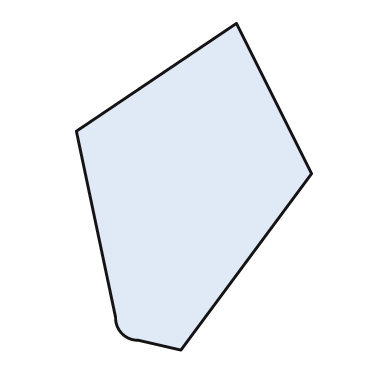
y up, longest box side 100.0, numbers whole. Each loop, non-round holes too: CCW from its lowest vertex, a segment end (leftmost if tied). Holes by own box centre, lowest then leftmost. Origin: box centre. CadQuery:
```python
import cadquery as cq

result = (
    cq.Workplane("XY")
    .moveTo(-4.0, -50.0)
    .lineTo(36.0, 4.0)
    .lineTo(13.0, 50.0)
    .lineTo(-36.0, 17.0)
    .lineTo(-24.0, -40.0)
    .threePointArc((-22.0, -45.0), (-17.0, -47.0))
    .close()
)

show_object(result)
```